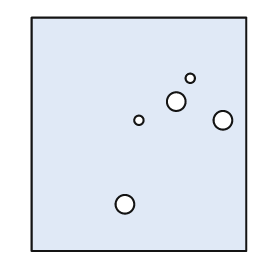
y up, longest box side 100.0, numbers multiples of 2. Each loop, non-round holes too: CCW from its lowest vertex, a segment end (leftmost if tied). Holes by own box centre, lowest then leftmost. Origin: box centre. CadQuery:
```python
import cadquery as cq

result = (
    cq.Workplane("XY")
    .moveTo(-46.0, -50.0)
    .lineTo(46.0, -50.0)
    .lineTo(46.0, 50.0)
    .lineTo(-46.0, 50.0)
    .close()
    .moveTo(-6.0, -30.0)
    .circle(4.0)
    .moveTo(0.0, 6.0)
    .circle(2.0)
    .moveTo(36.0, 6.0)
    .circle(4.0)
    .moveTo(16.0, 14.0)
    .circle(4.0)
    .moveTo(22.0, 24.0)
    .circle(2.0)
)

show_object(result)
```